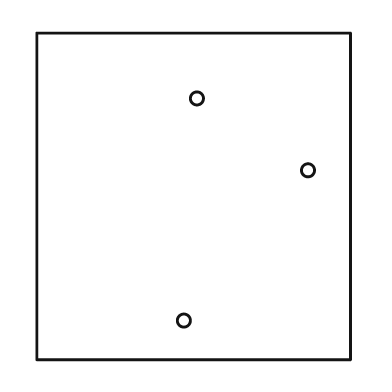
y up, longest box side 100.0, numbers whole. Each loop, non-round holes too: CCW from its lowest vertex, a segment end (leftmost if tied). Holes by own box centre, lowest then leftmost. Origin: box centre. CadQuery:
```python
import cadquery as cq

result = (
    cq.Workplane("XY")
    .moveTo(-48.0, -50.0)
    .lineTo(48.0, -50.0)
    .lineTo(48.0, 50.0)
    .lineTo(-48.0, 50.0)
    .close()
    .moveTo(-3.0, -38.0)
    .circle(2.0)
    .moveTo(35.0, 8.0)
    .circle(2.0)
    .moveTo(1.0, 30.0)
    .circle(2.0)
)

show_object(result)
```